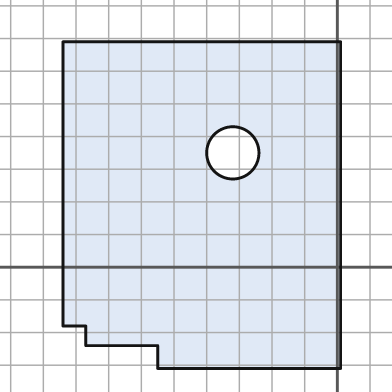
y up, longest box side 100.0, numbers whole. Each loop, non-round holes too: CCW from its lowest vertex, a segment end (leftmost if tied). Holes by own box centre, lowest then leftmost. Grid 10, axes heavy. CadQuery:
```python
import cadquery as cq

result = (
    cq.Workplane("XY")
    .moveTo(-55.0, -31.0)
    .lineTo(1.0, -31.0)
    .lineTo(1.0, 69.0)
    .lineTo(-84.0, 69.0)
    .lineTo(-84.0, -18.0)
    .lineTo(-77.0, -18.0)
    .lineTo(-77.0, -24.0)
    .lineTo(-55.0, -24.0)
    .close()
    .moveTo(-32.0, 35.0)
    .circle(8.0)
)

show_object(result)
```